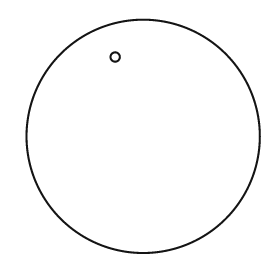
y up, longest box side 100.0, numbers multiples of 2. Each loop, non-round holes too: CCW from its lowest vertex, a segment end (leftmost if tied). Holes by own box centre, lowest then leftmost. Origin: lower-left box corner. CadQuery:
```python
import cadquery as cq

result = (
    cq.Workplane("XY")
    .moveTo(50.0, 50.0)
    .circle(50.0)
    .moveTo(38.0, 84.0)
    .circle(2.0)
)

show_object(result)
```